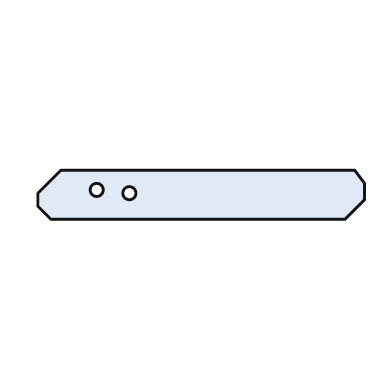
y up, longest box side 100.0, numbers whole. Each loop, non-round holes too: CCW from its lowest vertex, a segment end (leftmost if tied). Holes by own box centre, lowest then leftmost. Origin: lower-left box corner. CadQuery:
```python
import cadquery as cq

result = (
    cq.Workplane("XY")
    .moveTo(4.0, 0.0)
    .lineTo(94.0, 0.0)
    .lineTo(100.0, 6.0)
    .lineTo(100.0, 11.0)
    .lineTo(97.0, 15.0)
    .lineTo(7.0, 15.0)
    .lineTo(0.0, 8.0)
    .lineTo(0.0, 4.0)
    .close()
    .moveTo(28.0, 8.0)
    .circle(2.0)
    .moveTo(18.0, 9.0)
    .circle(2.0)
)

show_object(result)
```